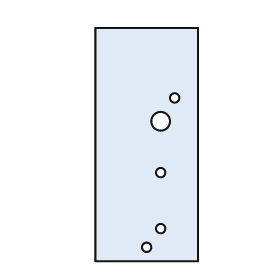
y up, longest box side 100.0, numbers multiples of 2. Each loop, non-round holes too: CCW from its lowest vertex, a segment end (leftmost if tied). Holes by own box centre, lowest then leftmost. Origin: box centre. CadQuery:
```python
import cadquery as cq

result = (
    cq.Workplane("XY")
    .moveTo(-22.0, -50.0)
    .lineTo(22.0, -50.0)
    .lineTo(22.0, 50.0)
    .lineTo(-22.0, 50.0)
    .close()
    .moveTo(0.0, -44.0)
    .circle(2.0)
    .moveTo(6.0, -36.0)
    .circle(2.0)
    .moveTo(6.0, -12.0)
    .circle(2.0)
    .moveTo(6.0, 10.0)
    .circle(4.0)
    .moveTo(12.0, 20.0)
    .circle(2.0)
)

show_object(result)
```